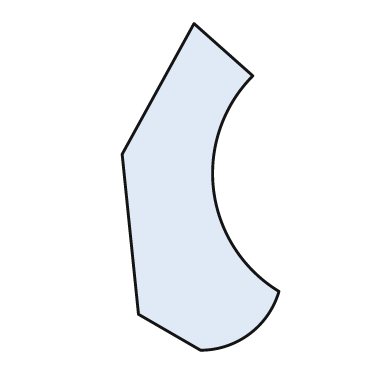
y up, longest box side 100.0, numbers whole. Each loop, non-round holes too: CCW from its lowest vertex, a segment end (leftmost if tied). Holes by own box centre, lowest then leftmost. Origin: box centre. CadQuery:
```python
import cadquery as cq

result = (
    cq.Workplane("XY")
    .moveTo(0.0, -50.0)
    .threePointArc((15.0, -45.0), (24.0, -32.0))
    .threePointArc((4.0, -1.0), (16.0, 34.0))
    .lineTo(-2.0, 50.0)
    .lineTo(-24.0, 10.0)
    .lineTo(-19.0, -39.0)
    .close()
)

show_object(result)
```